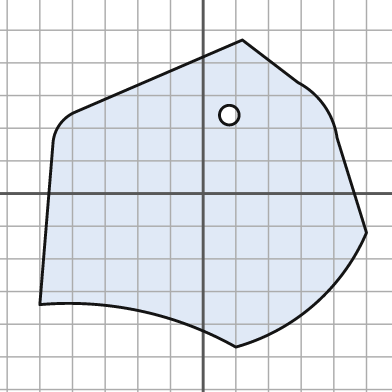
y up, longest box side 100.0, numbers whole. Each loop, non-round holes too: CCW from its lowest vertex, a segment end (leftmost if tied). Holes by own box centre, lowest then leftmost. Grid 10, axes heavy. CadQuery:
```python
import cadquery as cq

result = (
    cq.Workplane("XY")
    .moveTo(10.0, -47.0)
    .threePointArc((34.0, -34.0), (50.0, -12.0))
    .lineTo(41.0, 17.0)
    .threePointArc((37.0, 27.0), (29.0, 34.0))
    .lineTo(12.0, 47.0)
    .lineTo(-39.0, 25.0)
    .threePointArc((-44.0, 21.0), (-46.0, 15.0))
    .lineTo(-50.0, -34.0)
    .threePointArc((-19.0, -36.0), (10.0, -47.0))
    .close()
    .moveTo(8.0, 24.0)
    .circle(3.0)
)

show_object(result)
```